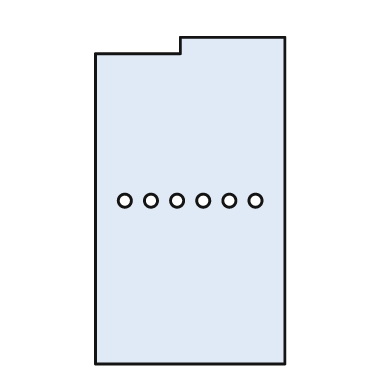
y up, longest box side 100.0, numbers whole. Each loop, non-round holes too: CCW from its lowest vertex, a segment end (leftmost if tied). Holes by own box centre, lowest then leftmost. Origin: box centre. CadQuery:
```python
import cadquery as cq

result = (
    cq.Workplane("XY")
    .moveTo(-29.0, -50.0)
    .lineTo(29.0, -50.0)
    .lineTo(29.0, 50.0)
    .lineTo(-3.0, 50.0)
    .lineTo(-3.0, 45.0)
    .lineTo(-29.0, 45.0)
    .close()
    .moveTo(-20.0, 0.0)
    .circle(2.0)
    .moveTo(-12.0, 0.0)
    .circle(2.0)
    .moveTo(-4.0, 0.0)
    .circle(2.0)
    .moveTo(4.0, 0.0)
    .circle(2.0)
    .moveTo(12.0, 0.0)
    .circle(2.0)
    .moveTo(20.0, 0.0)
    .circle(2.0)
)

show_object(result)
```